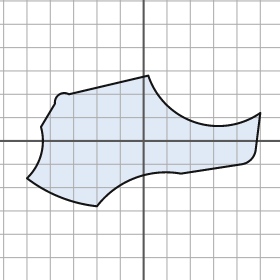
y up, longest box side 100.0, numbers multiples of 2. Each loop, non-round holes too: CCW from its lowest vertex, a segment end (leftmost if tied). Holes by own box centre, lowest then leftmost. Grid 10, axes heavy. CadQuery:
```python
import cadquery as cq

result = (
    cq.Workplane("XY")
    .moveTo(-20.0, -28.0)
    .threePointArc((-4.0, -16.0), (16.0, -14.0))
    .lineTo(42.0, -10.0)
    .threePointArc((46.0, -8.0), (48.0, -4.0))
    .lineTo(50.0, 12.0)
    .threePointArc((22.0, 8.0), (2.0, 28.0))
    .lineTo(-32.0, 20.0)
    .threePointArc((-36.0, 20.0), (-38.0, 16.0))
    .lineTo(-44.0, 6.0)
    .threePointArc((-44.0, -6.0), (-50.0, -16.0))
    .threePointArc((-36.0, -24.0), (-20.0, -28.0))
    .close()
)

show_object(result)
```